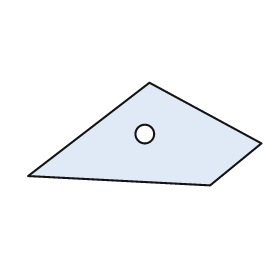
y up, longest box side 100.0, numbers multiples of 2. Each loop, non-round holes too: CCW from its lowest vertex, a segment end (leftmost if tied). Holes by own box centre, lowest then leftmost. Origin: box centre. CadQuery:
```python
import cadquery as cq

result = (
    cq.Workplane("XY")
    .moveTo(28.0, -22.0)
    .lineTo(50.0, -4.0)
    .lineTo(2.0, 22.0)
    .lineTo(-50.0, -18.0)
    .close()
    .moveTo(0.0, 0.0)
    .circle(4.0)
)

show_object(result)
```